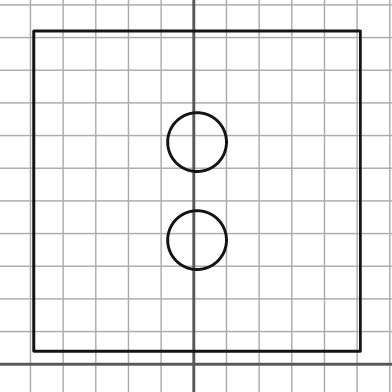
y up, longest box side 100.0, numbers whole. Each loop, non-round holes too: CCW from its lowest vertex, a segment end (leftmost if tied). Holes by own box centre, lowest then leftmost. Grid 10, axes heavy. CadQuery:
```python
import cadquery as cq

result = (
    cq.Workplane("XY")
    .moveTo(-49.0, 4.0)
    .lineTo(51.0, 4.0)
    .lineTo(51.0, 102.0)
    .lineTo(-49.0, 102.0)
    .close()
    .moveTo(1.0, 38.0)
    .circle(9.0)
    .moveTo(1.0, 68.0)
    .circle(9.0)
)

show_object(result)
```